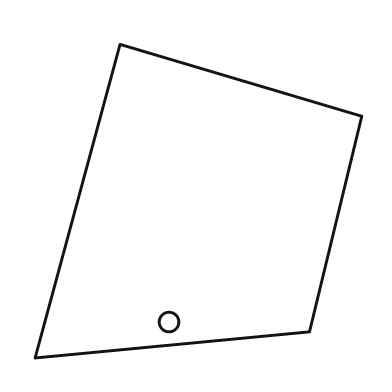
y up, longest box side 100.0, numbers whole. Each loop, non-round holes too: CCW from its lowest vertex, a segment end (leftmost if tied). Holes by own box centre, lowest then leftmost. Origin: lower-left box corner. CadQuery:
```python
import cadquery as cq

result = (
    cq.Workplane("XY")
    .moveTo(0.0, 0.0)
    .lineTo(84.0, 8.0)
    .lineTo(100.0, 74.0)
    .lineTo(26.0, 96.0)
    .close()
    .moveTo(41.0, 11.0)
    .circle(3.0)
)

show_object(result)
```